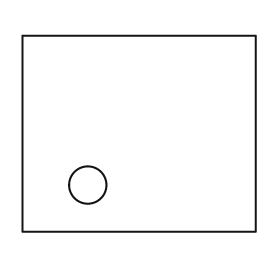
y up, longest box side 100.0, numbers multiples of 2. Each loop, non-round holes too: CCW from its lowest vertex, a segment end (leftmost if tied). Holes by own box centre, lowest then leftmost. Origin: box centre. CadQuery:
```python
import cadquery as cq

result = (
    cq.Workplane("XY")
    .moveTo(-50.0, -42.0)
    .lineTo(50.0, -42.0)
    .lineTo(50.0, 42.0)
    .lineTo(-50.0, 42.0)
    .close()
    .moveTo(-22.0, -22.0)
    .circle(8.0)
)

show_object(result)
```